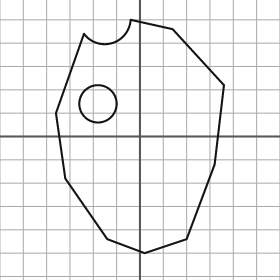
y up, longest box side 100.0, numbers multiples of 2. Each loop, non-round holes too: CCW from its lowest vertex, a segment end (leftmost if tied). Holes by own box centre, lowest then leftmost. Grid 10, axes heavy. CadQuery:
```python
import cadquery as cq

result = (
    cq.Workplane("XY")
    .moveTo(2.0, -50.0)
    .lineTo(20.0, -44.0)
    .lineTo(32.0, -12.0)
    .lineTo(36.0, 22.0)
    .lineTo(14.0, 46.0)
    .lineTo(-4.0, 50.0)
    .threePointArc((-12.0, 40.0), (-24.0, 44.0))
    .lineTo(-36.0, 10.0)
    .lineTo(-32.0, -18.0)
    .lineTo(-14.0, -44.0)
    .close()
    .moveTo(-18.0, 14.0)
    .circle(8.0)
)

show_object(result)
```